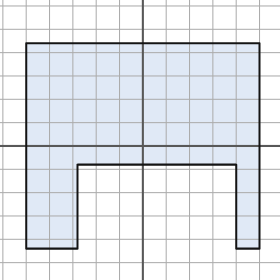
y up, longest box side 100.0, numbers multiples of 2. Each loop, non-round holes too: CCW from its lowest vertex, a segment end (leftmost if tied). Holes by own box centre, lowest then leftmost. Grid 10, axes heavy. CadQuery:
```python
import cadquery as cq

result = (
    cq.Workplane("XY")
    .moveTo(-50.0, -44.0)
    .lineTo(-28.0, -44.0)
    .lineTo(-28.0, -8.0)
    .lineTo(40.0, -8.0)
    .lineTo(40.0, -44.0)
    .lineTo(50.0, -44.0)
    .lineTo(50.0, 44.0)
    .lineTo(-50.0, 44.0)
    .close()
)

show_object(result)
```